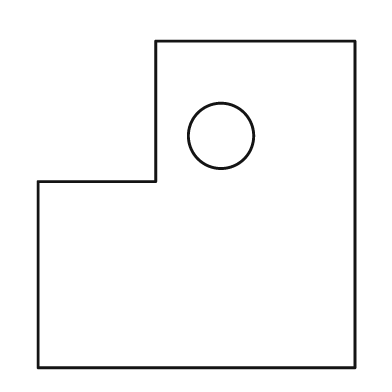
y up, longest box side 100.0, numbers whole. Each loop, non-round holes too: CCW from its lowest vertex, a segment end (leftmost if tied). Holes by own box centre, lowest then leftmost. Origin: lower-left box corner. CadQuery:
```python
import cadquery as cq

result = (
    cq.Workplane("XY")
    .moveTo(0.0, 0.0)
    .lineTo(97.0, 0.0)
    .lineTo(97.0, 100.0)
    .lineTo(36.0, 100.0)
    .lineTo(36.0, 57.0)
    .lineTo(0.0, 57.0)
    .close()
    .moveTo(56.0, 71.0)
    .circle(10.0)
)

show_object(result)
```